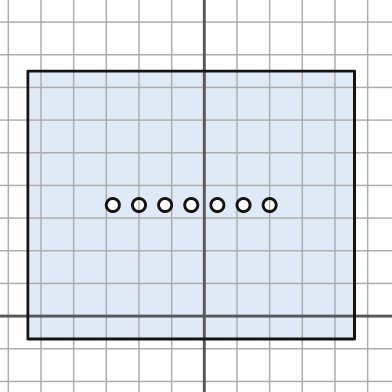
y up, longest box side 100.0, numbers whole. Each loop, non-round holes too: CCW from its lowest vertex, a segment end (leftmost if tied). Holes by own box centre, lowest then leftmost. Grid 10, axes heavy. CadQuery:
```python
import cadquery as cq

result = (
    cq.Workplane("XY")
    .moveTo(-54.0, -7.0)
    .lineTo(46.0, -7.0)
    .lineTo(46.0, 75.0)
    .lineTo(-54.0, 75.0)
    .close()
    .moveTo(-28.0, 34.0)
    .circle(2.0)
    .moveTo(-20.0, 34.0)
    .circle(2.0)
    .moveTo(-12.0, 34.0)
    .circle(2.0)
    .moveTo(-4.0, 34.0)
    .circle(2.0)
    .moveTo(4.0, 34.0)
    .circle(2.0)
    .moveTo(12.0, 34.0)
    .circle(2.0)
    .moveTo(20.0, 34.0)
    .circle(2.0)
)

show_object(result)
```